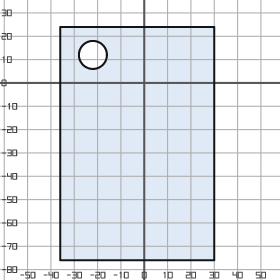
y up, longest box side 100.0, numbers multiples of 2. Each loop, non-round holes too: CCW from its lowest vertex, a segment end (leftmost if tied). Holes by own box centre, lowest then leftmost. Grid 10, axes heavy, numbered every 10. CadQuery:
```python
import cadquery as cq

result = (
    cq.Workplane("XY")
    .moveTo(-36.0, -76.0)
    .lineTo(30.0, -76.0)
    .lineTo(30.0, 24.0)
    .lineTo(-36.0, 24.0)
    .close()
    .moveTo(-22.0, 12.0)
    .circle(6.0)
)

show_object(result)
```